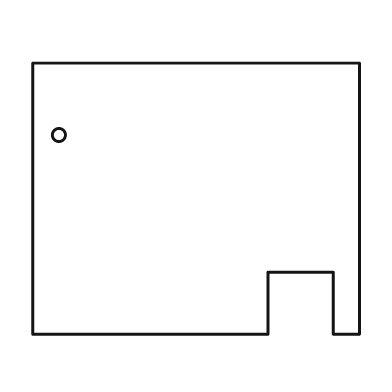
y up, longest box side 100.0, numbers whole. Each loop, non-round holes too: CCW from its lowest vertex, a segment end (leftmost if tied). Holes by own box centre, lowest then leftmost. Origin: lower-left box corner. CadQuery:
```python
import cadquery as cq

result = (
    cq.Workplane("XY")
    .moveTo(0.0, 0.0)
    .lineTo(72.0, 0.0)
    .lineTo(72.0, 19.0)
    .lineTo(92.0, 19.0)
    .lineTo(92.0, 0.0)
    .lineTo(100.0, 0.0)
    .lineTo(100.0, 83.0)
    .lineTo(0.0, 83.0)
    .close()
    .moveTo(8.0, 61.0)
    .circle(2.0)
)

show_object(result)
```